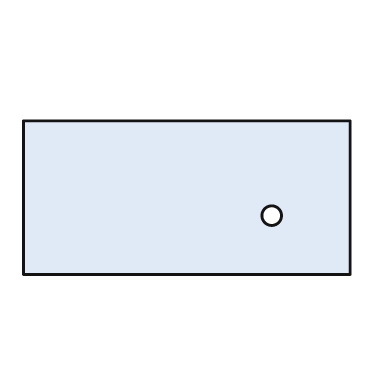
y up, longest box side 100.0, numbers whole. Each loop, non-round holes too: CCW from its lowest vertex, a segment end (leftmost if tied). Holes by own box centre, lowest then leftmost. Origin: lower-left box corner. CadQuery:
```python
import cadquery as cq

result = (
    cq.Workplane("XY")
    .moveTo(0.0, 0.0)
    .lineTo(100.0, 0.0)
    .lineTo(100.0, 47.0)
    .lineTo(0.0, 47.0)
    .close()
    .moveTo(76.0, 18.0)
    .circle(3.0)
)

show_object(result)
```